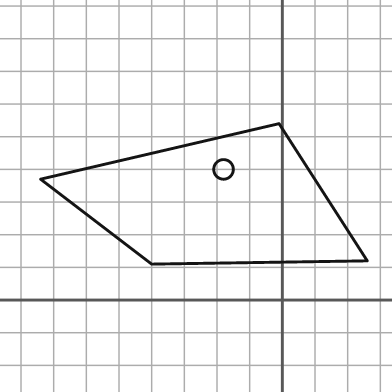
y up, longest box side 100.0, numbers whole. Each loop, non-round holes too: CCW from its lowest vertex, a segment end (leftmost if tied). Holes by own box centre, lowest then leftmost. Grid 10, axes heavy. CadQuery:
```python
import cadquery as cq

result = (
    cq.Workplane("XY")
    .moveTo(-40.0, 11.0)
    .lineTo(26.0, 12.0)
    .lineTo(-1.0, 54.0)
    .lineTo(-74.0, 37.0)
    .close()
    .moveTo(-18.0, 40.0)
    .circle(3.0)
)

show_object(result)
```